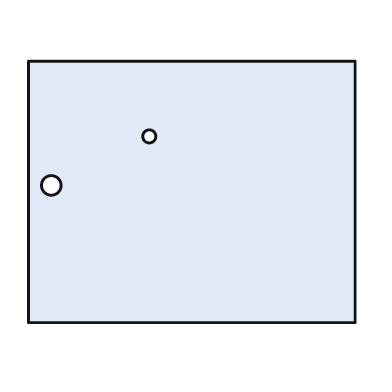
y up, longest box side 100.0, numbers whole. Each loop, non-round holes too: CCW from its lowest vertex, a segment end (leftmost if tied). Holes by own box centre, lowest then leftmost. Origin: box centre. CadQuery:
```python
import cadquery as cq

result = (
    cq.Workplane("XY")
    .moveTo(-50.0, -40.0)
    .lineTo(50.0, -40.0)
    .lineTo(50.0, 40.0)
    .lineTo(-50.0, 40.0)
    .close()
    .moveTo(-43.0, 2.0)
    .circle(3.0)
    .moveTo(-13.0, 17.0)
    .circle(2.0)
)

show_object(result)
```